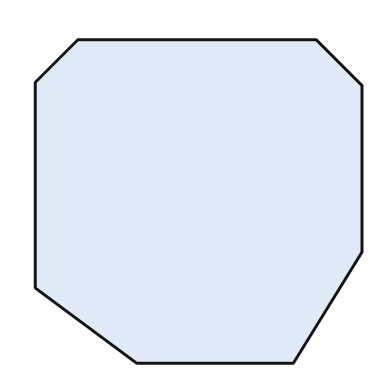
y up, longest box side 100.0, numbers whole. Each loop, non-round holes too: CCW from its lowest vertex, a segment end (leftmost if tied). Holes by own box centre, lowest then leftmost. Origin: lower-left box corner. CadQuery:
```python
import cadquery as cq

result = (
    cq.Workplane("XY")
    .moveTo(31.0, 0.0)
    .lineTo(79.0, 0.0)
    .lineTo(100.0, 34.0)
    .lineTo(100.0, 85.0)
    .lineTo(86.0, 99.0)
    .lineTo(13.0, 99.0)
    .lineTo(0.0, 86.0)
    .lineTo(0.0, 23.0)
    .close()
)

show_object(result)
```